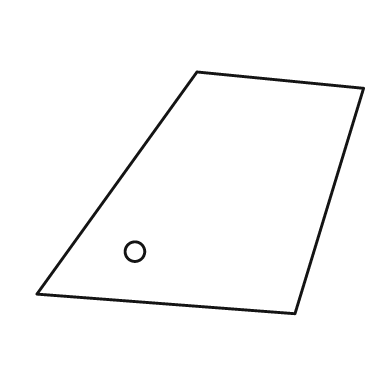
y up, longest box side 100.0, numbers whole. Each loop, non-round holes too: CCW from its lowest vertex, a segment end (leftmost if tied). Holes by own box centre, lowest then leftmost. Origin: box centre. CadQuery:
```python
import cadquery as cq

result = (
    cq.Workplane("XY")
    .moveTo(29.0, -37.0)
    .lineTo(50.0, 32.0)
    .lineTo(-1.0, 37.0)
    .lineTo(-50.0, -31.0)
    .close()
    .moveTo(-20.0, -18.0)
    .circle(3.0)
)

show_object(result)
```